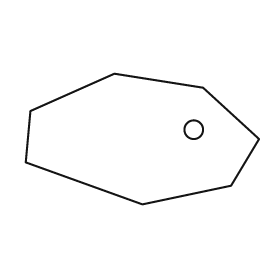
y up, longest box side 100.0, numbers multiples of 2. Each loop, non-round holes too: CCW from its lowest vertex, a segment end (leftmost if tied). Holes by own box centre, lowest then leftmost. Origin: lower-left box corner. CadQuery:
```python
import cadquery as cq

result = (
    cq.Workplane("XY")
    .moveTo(50.0, 0.0)
    .lineTo(88.0, 8.0)
    .lineTo(100.0, 28.0)
    .lineTo(76.0, 50.0)
    .lineTo(38.0, 56.0)
    .lineTo(2.0, 40.0)
    .lineTo(0.0, 18.0)
    .close()
    .moveTo(72.0, 32.0)
    .circle(4.0)
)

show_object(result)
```